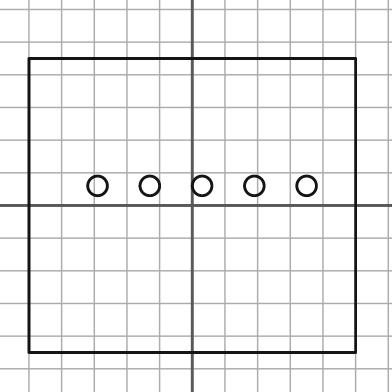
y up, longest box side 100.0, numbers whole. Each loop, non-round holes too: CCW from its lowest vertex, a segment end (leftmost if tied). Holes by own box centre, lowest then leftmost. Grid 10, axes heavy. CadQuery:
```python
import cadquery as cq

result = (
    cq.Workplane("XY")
    .moveTo(-50.0, -45.0)
    .lineTo(50.0, -45.0)
    .lineTo(50.0, 45.0)
    .lineTo(-50.0, 45.0)
    .close()
    .moveTo(-29.0, 6.0)
    .circle(3.0)
    .moveTo(-13.0, 6.0)
    .circle(3.0)
    .moveTo(3.0, 6.0)
    .circle(3.0)
    .moveTo(19.0, 6.0)
    .circle(3.0)
    .moveTo(35.0, 6.0)
    .circle(3.0)
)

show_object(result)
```